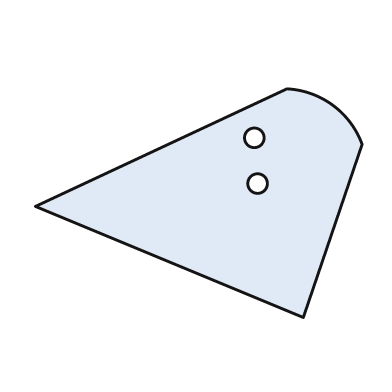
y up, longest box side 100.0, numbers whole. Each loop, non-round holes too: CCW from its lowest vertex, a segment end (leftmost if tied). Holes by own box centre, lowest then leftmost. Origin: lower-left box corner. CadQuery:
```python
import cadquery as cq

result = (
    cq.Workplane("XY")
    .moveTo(82.0, 0.0)
    .lineTo(100.0, 53.0)
    .threePointArc((91.0, 65.0), (77.0, 70.0))
    .lineTo(0.0, 34.0)
    .close()
    .moveTo(68.0, 41.0)
    .circle(3.0)
    .moveTo(67.0, 55.0)
    .circle(3.0)
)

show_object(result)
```